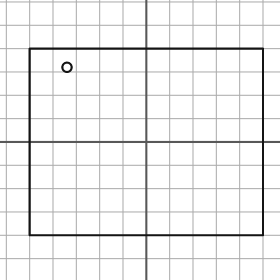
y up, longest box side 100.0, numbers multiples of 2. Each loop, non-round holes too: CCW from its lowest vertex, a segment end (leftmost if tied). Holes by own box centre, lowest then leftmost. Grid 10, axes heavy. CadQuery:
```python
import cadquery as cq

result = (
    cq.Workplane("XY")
    .moveTo(-50.0, -40.0)
    .lineTo(50.0, -40.0)
    .lineTo(50.0, 40.0)
    .lineTo(-50.0, 40.0)
    .close()
    .moveTo(-34.0, 32.0)
    .circle(2.0)
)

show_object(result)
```